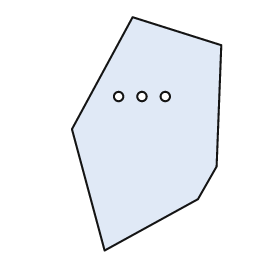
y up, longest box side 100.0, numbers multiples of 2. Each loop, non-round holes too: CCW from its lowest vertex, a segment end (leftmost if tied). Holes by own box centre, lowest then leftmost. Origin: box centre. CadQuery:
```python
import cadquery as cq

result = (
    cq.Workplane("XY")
    .moveTo(-18.0, -50.0)
    .lineTo(22.0, -28.0)
    .lineTo(30.0, -14.0)
    .lineTo(32.0, 38.0)
    .lineTo(-6.0, 50.0)
    .lineTo(-32.0, 2.0)
    .close()
    .moveTo(-12.0, 16.0)
    .circle(2.0)
    .moveTo(-2.0, 16.0)
    .circle(2.0)
    .moveTo(8.0, 16.0)
    .circle(2.0)
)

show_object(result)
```